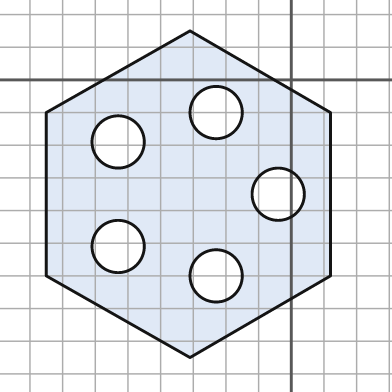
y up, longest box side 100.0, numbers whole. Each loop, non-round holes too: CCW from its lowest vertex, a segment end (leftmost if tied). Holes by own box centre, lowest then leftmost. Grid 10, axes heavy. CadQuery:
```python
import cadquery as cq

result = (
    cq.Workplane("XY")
    .moveTo(-31.0, -85.0)
    .lineTo(12.0, -60.0)
    .lineTo(12.0, -10.0)
    .lineTo(-31.0, 15.0)
    .lineTo(-75.0, -10.0)
    .lineTo(-75.0, -60.0)
    .close()
    .moveTo(-23.0, -60.0)
    .circle(8.0)
    .moveTo(-53.0, -51.0)
    .circle(8.0)
    .moveTo(-4.0, -35.0)
    .circle(8.0)
    .moveTo(-53.0, -19.0)
    .circle(8.0)
    .moveTo(-23.0, -10.0)
    .circle(8.0)
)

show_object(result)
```